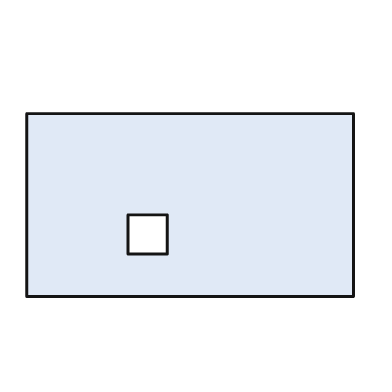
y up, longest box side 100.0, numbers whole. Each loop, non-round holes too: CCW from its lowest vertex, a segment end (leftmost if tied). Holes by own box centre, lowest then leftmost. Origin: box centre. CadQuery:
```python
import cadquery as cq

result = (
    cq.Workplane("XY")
    .moveTo(-50.0, -28.0)
    .lineTo(50.0, -28.0)
    .lineTo(50.0, 28.0)
    .lineTo(-50.0, 28.0)
    .close()
    .moveTo(-19.0, -15.0)
    .lineTo(-7.0, -15.0)
    .lineTo(-7.0, -3.0)
    .lineTo(-19.0, -3.0)
    .close()
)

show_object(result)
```